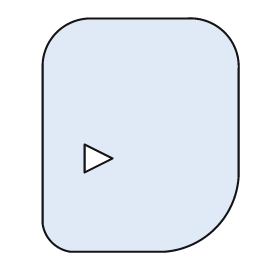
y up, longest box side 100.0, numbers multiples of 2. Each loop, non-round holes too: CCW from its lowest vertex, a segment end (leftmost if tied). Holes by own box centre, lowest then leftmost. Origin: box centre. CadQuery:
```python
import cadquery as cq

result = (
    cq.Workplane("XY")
    .moveTo(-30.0, -50.0)
    .lineTo(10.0, -50.0)
    .threePointArc((32.0, -40.0), (42.0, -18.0))
    .lineTo(42.0, 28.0)
    .threePointArc((36.0, 44.0), (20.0, 50.0))
    .lineTo(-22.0, 50.0)
    .threePointArc((-36.0, 44.0), (-42.0, 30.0))
    .lineTo(-42.0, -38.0)
    .threePointArc((-38.0, -46.0), (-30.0, -50.0))
    .close()
    .moveTo(-24.0, -16.0)
    .lineTo(-12.0, -10.0)
    .lineTo(-24.0, -4.0)
    .close()
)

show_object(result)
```